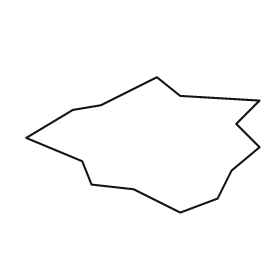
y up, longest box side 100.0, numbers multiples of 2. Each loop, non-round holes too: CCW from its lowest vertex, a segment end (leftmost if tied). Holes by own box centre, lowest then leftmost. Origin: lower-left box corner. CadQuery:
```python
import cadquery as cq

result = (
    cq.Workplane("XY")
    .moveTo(66.0, 0.0)
    .lineTo(82.0, 6.0)
    .lineTo(88.0, 18.0)
    .lineTo(100.0, 28.0)
    .lineTo(90.0, 38.0)
    .lineTo(100.0, 48.0)
    .lineTo(66.0, 50.0)
    .lineTo(56.0, 58.0)
    .lineTo(32.0, 46.0)
    .lineTo(20.0, 44.0)
    .lineTo(0.0, 32.0)
    .lineTo(24.0, 22.0)
    .lineTo(28.0, 12.0)
    .lineTo(46.0, 10.0)
    .close()
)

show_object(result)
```